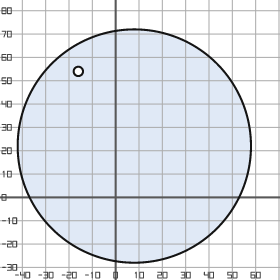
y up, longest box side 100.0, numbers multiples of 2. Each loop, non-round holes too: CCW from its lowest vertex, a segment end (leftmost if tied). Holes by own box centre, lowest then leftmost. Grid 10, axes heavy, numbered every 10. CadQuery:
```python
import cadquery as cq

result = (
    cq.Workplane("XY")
    .moveTo(8.0, 22.0)
    .circle(50.0)
    .moveTo(-16.0, 54.0)
    .circle(2.0)
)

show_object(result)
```